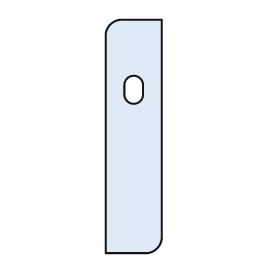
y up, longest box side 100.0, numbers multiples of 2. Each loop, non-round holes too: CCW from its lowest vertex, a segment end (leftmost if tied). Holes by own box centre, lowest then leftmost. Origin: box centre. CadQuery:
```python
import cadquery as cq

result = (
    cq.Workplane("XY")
    .moveTo(-12.0, -50.0)
    .lineTo(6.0, -50.0)
    .threePointArc((10.0, -48.0), (12.0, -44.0))
    .lineTo(12.0, 50.0)
    .lineTo(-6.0, 50.0)
    .threePointArc((-10.0, 48.0), (-12.0, 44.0))
    .close()
    .moveTo(-4.0, 18.0)
    .threePointArc((0.0, 14.0), (4.0, 18.0))
    .lineTo(4.0, 22.0)
    .threePointArc((0.0, 26.0), (-4.0, 22.0))
    .close()
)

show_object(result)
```